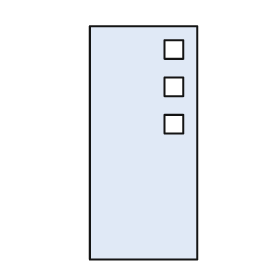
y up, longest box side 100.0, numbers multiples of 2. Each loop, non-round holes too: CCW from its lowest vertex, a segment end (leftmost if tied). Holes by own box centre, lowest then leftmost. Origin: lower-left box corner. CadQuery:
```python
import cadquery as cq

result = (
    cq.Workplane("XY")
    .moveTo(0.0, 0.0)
    .lineTo(46.0, 0.0)
    .lineTo(46.0, 100.0)
    .lineTo(0.0, 100.0)
    .close()
    .moveTo(32.0, 54.0)
    .lineTo(40.0, 54.0)
    .lineTo(40.0, 62.0)
    .lineTo(32.0, 62.0)
    .close()
    .moveTo(32.0, 70.0)
    .lineTo(40.0, 70.0)
    .lineTo(40.0, 78.0)
    .lineTo(32.0, 78.0)
    .close()
    .moveTo(32.0, 86.0)
    .lineTo(40.0, 86.0)
    .lineTo(40.0, 94.0)
    .lineTo(32.0, 94.0)
    .close()
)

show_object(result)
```